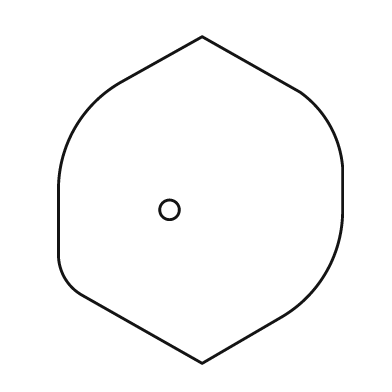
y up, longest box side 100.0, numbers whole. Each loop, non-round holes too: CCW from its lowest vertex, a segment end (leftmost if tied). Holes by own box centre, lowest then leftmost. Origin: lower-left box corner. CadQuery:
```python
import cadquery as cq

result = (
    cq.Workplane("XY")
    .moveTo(44.0, 0.0)
    .lineTo(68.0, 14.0)
    .threePointArc((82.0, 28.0), (87.0, 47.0))
    .lineTo(87.0, 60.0)
    .threePointArc((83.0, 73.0), (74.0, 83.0))
    .lineTo(44.0, 100.0)
    .lineTo(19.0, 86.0)
    .threePointArc((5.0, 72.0), (0.0, 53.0))
    .lineTo(0.0, 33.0)
    .threePointArc((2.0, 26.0), (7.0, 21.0))
    .close()
    .moveTo(34.0, 47.0)
    .circle(3.0)
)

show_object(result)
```